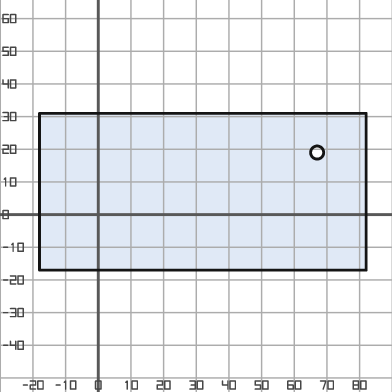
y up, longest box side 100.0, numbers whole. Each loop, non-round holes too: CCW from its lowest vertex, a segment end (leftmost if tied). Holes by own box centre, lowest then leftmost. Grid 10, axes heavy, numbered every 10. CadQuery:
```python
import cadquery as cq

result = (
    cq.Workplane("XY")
    .moveTo(-18.0, -17.0)
    .lineTo(82.0, -17.0)
    .lineTo(82.0, 31.0)
    .lineTo(-18.0, 31.0)
    .close()
    .moveTo(67.0, 19.0)
    .circle(2.0)
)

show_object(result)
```